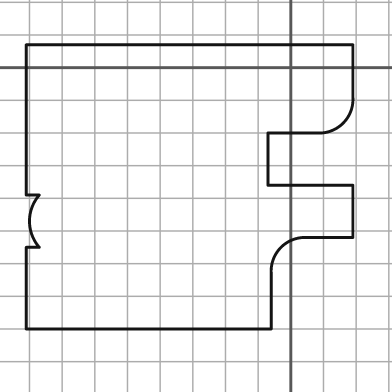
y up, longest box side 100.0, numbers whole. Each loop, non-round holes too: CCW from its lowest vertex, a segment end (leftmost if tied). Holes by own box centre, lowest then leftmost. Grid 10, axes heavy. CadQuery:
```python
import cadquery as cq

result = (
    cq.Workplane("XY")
    .moveTo(-81.0, -80.0)
    .lineTo(-6.0, -80.0)
    .lineTo(-6.0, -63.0)
    .threePointArc((-3.0, -55.0), (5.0, -52.0))
    .lineTo(19.0, -52.0)
    .lineTo(19.0, -36.0)
    .lineTo(-7.0, -36.0)
    .lineTo(-7.0, -20.0)
    .lineTo(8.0, -20.0)
    .threePointArc((16.0, -17.0), (19.0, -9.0))
    .lineTo(19.0, 7.0)
    .lineTo(-81.0, 7.0)
    .lineTo(-81.0, -39.0)
    .lineTo(-77.0, -39.0)
    .threePointArc((-80.0, -47.0), (-77.0, -55.0))
    .lineTo(-81.0, -55.0)
    .close()
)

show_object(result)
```